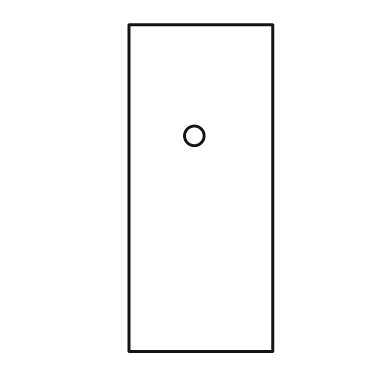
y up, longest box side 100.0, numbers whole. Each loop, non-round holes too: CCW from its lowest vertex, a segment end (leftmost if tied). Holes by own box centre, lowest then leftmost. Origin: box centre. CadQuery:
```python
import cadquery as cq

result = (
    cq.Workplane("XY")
    .moveTo(-22.0, -50.0)
    .lineTo(22.0, -50.0)
    .lineTo(22.0, 50.0)
    .lineTo(-22.0, 50.0)
    .close()
    .moveTo(-2.0, 16.0)
    .circle(3.0)
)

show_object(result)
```